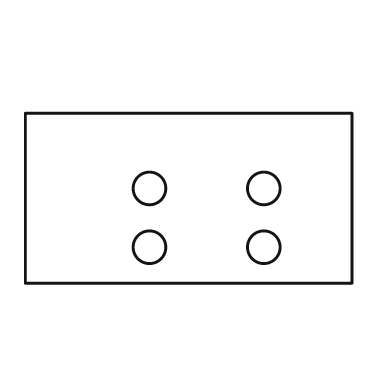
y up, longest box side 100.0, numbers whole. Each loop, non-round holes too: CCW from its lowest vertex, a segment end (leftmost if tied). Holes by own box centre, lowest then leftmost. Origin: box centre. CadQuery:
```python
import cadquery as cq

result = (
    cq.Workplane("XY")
    .moveTo(-50.0, -26.0)
    .lineTo(50.0, -26.0)
    .lineTo(50.0, 26.0)
    .lineTo(-50.0, 26.0)
    .close()
    .moveTo(-12.0, -15.0)
    .circle(5.0)
    .moveTo(23.0, -15.0)
    .circle(5.0)
    .moveTo(-12.0, 3.0)
    .circle(5.0)
    .moveTo(23.0, 3.0)
    .circle(5.0)
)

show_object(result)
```